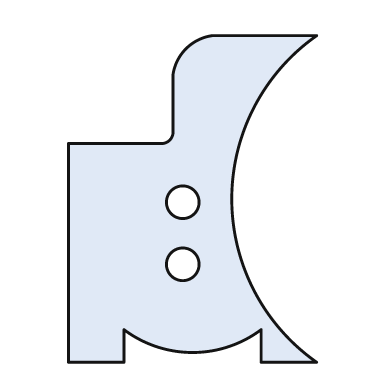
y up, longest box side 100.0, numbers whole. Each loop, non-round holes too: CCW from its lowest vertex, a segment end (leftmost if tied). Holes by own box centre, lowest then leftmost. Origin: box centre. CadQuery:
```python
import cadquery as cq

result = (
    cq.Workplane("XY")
    .moveTo(-38.0, -50.0)
    .lineTo(-21.0, -50.0)
    .lineTo(-21.0, -40.0)
    .threePointArc((0.0, -47.0), (21.0, -40.0))
    .lineTo(21.0, -50.0)
    .lineTo(38.0, -50.0)
    .threePointArc((12.0, 0.0), (38.0, 50.0))
    .lineTo(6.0, 50.0)
    .threePointArc((-2.0, 46.0), (-6.0, 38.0))
    .lineTo(-6.0, 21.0)
    .threePointArc((-7.0, 18.0), (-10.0, 17.0))
    .lineTo(-38.0, 17.0)
    .close()
    .moveTo(-3.0, -20.0)
    .circle(5.0)
    .moveTo(-3.0, -1.0)
    .circle(5.0)
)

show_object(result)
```